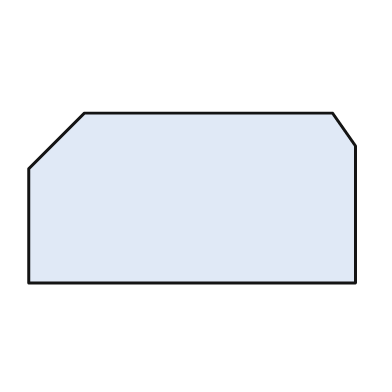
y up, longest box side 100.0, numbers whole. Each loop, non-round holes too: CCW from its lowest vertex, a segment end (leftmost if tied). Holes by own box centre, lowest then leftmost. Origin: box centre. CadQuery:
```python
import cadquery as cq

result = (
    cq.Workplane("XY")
    .moveTo(-50.0, -26.0)
    .lineTo(50.0, -26.0)
    .lineTo(50.0, 16.0)
    .lineTo(43.0, 26.0)
    .lineTo(-33.0, 26.0)
    .lineTo(-50.0, 9.0)
    .close()
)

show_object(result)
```